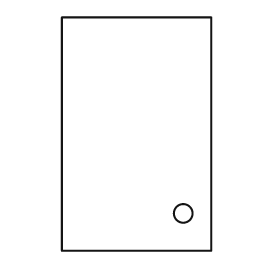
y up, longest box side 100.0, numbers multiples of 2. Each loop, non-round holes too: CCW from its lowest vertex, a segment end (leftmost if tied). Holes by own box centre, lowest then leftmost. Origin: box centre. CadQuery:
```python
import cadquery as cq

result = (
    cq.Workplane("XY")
    .moveTo(-32.0, -50.0)
    .lineTo(32.0, -50.0)
    .lineTo(32.0, 50.0)
    .lineTo(-32.0, 50.0)
    .close()
    .moveTo(20.0, -34.0)
    .circle(4.0)
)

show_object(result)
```